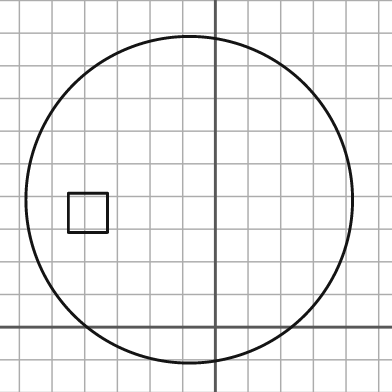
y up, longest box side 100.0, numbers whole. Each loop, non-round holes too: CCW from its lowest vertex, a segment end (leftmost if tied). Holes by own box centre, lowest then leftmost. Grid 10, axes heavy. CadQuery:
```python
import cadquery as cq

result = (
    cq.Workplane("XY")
    .moveTo(-8.0, 39.0)
    .circle(50.0)
    .moveTo(-45.0, 29.0)
    .lineTo(-33.0, 29.0)
    .lineTo(-33.0, 41.0)
    .lineTo(-45.0, 41.0)
    .close()
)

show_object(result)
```